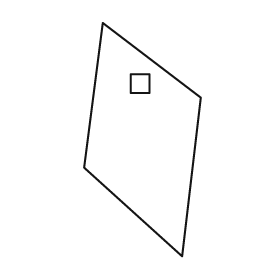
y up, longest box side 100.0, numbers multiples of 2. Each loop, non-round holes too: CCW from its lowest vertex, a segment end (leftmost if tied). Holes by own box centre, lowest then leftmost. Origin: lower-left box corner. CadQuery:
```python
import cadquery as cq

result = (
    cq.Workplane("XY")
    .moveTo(42.0, 0.0)
    .lineTo(50.0, 68.0)
    .lineTo(8.0, 100.0)
    .lineTo(0.0, 38.0)
    .close()
    .moveTo(20.0, 70.0)
    .lineTo(28.0, 70.0)
    .lineTo(28.0, 78.0)
    .lineTo(20.0, 78.0)
    .close()
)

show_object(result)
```